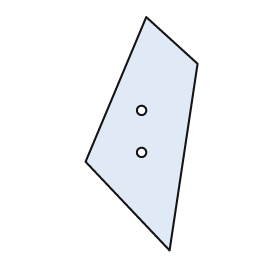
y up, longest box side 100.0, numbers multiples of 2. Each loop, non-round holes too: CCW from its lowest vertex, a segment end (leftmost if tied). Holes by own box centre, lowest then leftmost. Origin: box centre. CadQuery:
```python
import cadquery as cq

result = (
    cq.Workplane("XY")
    .moveTo(12.0, -50.0)
    .lineTo(24.0, 30.0)
    .lineTo(2.0, 50.0)
    .lineTo(-24.0, -12.0)
    .close()
    .moveTo(0.0, -8.0)
    .circle(2.0)
    .moveTo(0.0, 10.0)
    .circle(2.0)
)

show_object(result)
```